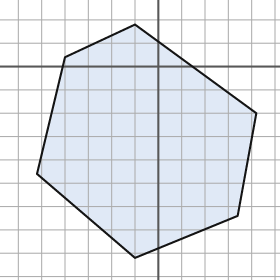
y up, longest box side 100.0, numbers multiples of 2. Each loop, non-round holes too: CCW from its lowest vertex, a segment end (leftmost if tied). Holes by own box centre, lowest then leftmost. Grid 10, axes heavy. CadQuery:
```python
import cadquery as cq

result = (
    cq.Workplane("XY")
    .moveTo(-10.0, -82.0)
    .lineTo(34.0, -64.0)
    .lineTo(42.0, -20.0)
    .lineTo(-10.0, 18.0)
    .lineTo(-40.0, 4.0)
    .lineTo(-52.0, -46.0)
    .close()
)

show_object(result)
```